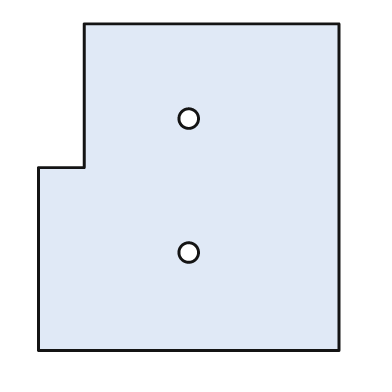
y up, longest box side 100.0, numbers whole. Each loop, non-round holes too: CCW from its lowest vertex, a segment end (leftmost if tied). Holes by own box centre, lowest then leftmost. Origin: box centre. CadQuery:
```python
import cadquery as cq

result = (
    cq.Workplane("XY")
    .moveTo(-46.0, -50.0)
    .lineTo(46.0, -50.0)
    .lineTo(46.0, 50.0)
    .lineTo(-32.0, 50.0)
    .lineTo(-32.0, 6.0)
    .lineTo(-46.0, 6.0)
    .close()
    .moveTo(0.0, -20.0)
    .circle(3.0)
    .moveTo(0.0, 21.0)
    .circle(3.0)
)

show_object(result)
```